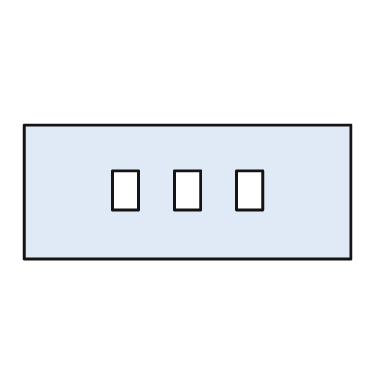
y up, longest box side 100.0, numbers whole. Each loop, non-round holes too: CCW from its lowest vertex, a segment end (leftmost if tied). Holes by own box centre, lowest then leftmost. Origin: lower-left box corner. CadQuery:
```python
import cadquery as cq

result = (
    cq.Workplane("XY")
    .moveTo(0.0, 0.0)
    .lineTo(100.0, 0.0)
    .lineTo(100.0, 41.0)
    .lineTo(0.0, 41.0)
    .close()
    .moveTo(27.0, 15.0)
    .lineTo(35.0, 15.0)
    .lineTo(35.0, 27.0)
    .lineTo(27.0, 27.0)
    .close()
    .moveTo(46.0, 15.0)
    .lineTo(54.0, 15.0)
    .lineTo(54.0, 27.0)
    .lineTo(46.0, 27.0)
    .close()
    .moveTo(65.0, 15.0)
    .lineTo(73.0, 15.0)
    .lineTo(73.0, 27.0)
    .lineTo(65.0, 27.0)
    .close()
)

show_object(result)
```